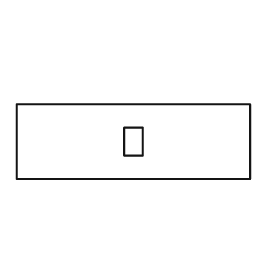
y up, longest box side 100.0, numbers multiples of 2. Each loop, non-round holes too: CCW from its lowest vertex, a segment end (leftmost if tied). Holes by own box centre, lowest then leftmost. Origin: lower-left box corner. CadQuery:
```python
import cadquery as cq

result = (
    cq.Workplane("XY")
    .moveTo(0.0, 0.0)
    .lineTo(100.0, 0.0)
    .lineTo(100.0, 32.0)
    .lineTo(0.0, 32.0)
    .close()
    .moveTo(46.0, 10.0)
    .lineTo(54.0, 10.0)
    .lineTo(54.0, 22.0)
    .lineTo(46.0, 22.0)
    .close()
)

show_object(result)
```